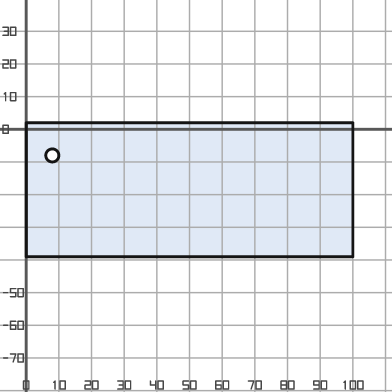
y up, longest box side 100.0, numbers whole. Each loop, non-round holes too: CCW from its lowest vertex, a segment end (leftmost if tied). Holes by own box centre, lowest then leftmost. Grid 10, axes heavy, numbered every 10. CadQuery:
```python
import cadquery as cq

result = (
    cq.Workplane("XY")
    .moveTo(0.0, -39.0)
    .lineTo(100.0, -39.0)
    .lineTo(100.0, 2.0)
    .lineTo(0.0, 2.0)
    .close()
    .moveTo(8.0, -8.0)
    .circle(2.0)
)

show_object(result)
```